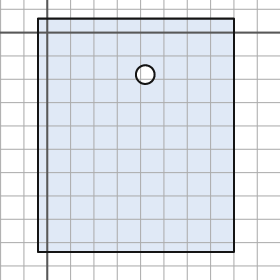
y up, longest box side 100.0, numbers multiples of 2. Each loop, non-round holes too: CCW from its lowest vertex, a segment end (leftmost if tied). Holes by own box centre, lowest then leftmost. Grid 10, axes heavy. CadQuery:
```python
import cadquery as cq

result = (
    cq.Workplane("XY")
    .moveTo(-4.0, -94.0)
    .lineTo(80.0, -94.0)
    .lineTo(80.0, 6.0)
    .lineTo(-4.0, 6.0)
    .close()
    .moveTo(42.0, -18.0)
    .circle(4.0)
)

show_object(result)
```